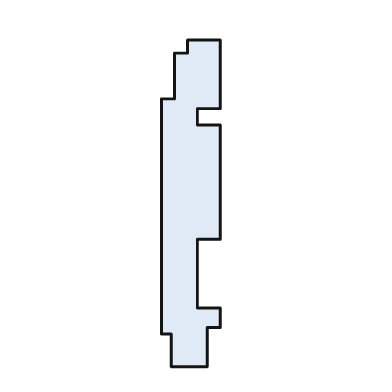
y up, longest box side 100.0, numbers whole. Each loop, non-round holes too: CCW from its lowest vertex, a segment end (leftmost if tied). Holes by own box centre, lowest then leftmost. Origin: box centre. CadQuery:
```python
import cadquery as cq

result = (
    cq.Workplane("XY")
    .moveTo(-6.0, -50.0)
    .lineTo(5.0, -50.0)
    .lineTo(5.0, -38.0)
    .lineTo(9.0, -38.0)
    .lineTo(9.0, -32.0)
    .lineTo(2.0, -32.0)
    .lineTo(2.0, -11.0)
    .lineTo(9.0, -11.0)
    .lineTo(9.0, 24.0)
    .lineTo(2.0, 24.0)
    .lineTo(2.0, 29.0)
    .lineTo(9.0, 29.0)
    .lineTo(9.0, 50.0)
    .lineTo(-1.0, 50.0)
    .lineTo(-1.0, 46.0)
    .lineTo(-5.0, 46.0)
    .lineTo(-5.0, 32.0)
    .lineTo(-9.0, 32.0)
    .lineTo(-9.0, -40.0)
    .lineTo(-6.0, -40.0)
    .close()
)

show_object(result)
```